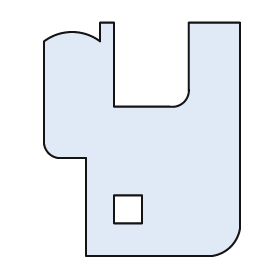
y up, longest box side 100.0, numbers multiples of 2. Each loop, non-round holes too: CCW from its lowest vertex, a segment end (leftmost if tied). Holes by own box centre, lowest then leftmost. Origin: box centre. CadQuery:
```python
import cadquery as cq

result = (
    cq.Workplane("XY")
    .moveTo(-24.0, -50.0)
    .lineTo(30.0, -50.0)
    .threePointArc((38.0, -46.0), (42.0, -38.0))
    .lineTo(42.0, 50.0)
    .lineTo(20.0, 50.0)
    .lineTo(20.0, 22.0)
    .threePointArc((18.0, 16.0), (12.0, 14.0))
    .lineTo(-12.0, 14.0)
    .lineTo(-12.0, 50.0)
    .lineTo(-18.0, 50.0)
    .lineTo(-18.0, 42.0)
    .threePointArc((-30.0, 46.0), (-42.0, 42.0))
    .lineTo(-42.0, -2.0)
    .threePointArc((-40.0, -6.0), (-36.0, -8.0))
    .lineTo(-24.0, -8.0)
    .close()
    .moveTo(-12.0, -36.0)
    .lineTo(0.0, -36.0)
    .lineTo(0.0, -24.0)
    .lineTo(-12.0, -24.0)
    .close()
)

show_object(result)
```